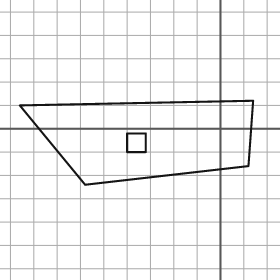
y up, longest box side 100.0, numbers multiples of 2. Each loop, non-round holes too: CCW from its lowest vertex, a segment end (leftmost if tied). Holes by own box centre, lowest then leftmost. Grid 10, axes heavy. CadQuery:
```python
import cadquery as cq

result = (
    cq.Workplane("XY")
    .moveTo(-58.0, -24.0)
    .lineTo(12.0, -16.0)
    .lineTo(14.0, 12.0)
    .lineTo(-86.0, 10.0)
    .close()
    .moveTo(-40.0, -10.0)
    .lineTo(-32.0, -10.0)
    .lineTo(-32.0, -2.0)
    .lineTo(-40.0, -2.0)
    .close()
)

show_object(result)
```